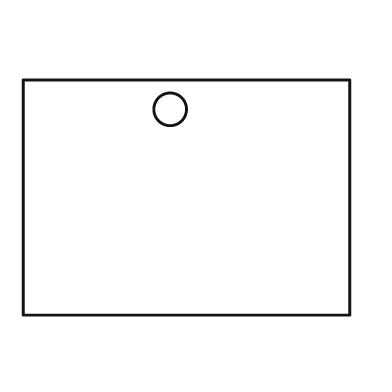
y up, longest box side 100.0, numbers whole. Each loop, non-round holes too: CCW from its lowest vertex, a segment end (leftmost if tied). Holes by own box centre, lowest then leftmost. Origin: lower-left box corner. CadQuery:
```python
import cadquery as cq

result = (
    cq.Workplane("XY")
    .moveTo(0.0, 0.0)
    .lineTo(100.0, 0.0)
    .lineTo(100.0, 72.0)
    .lineTo(0.0, 72.0)
    .close()
    .moveTo(45.0, 63.0)
    .circle(5.0)
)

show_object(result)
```